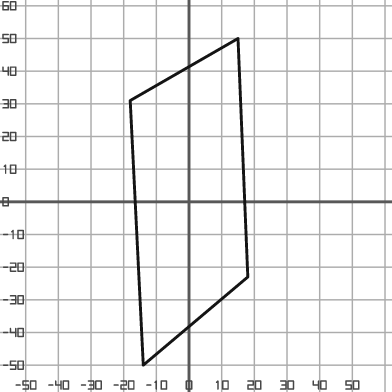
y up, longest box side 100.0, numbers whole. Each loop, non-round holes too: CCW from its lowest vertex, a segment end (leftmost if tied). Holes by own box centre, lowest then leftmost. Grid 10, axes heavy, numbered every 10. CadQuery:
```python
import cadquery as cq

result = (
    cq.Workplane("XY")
    .moveTo(-14.0, -50.0)
    .lineTo(18.0, -23.0)
    .lineTo(15.0, 50.0)
    .lineTo(-18.0, 31.0)
    .close()
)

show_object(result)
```